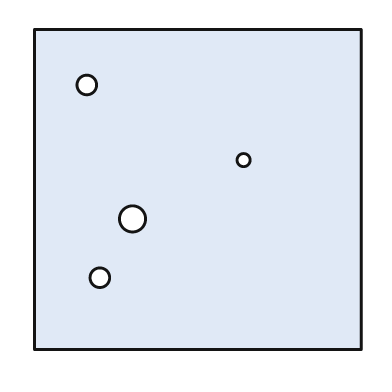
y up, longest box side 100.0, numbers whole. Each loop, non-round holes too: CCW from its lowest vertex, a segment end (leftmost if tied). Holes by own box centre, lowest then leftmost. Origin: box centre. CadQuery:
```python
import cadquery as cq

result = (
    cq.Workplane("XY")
    .moveTo(-50.0, -49.0)
    .lineTo(50.0, -49.0)
    .lineTo(50.0, 49.0)
    .lineTo(-50.0, 49.0)
    .close()
    .moveTo(-30.0, -27.0)
    .circle(3.0)
    .moveTo(-20.0, -9.0)
    .circle(4.0)
    .moveTo(14.0, 9.0)
    .circle(2.0)
    .moveTo(-34.0, 32.0)
    .circle(3.0)
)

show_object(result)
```